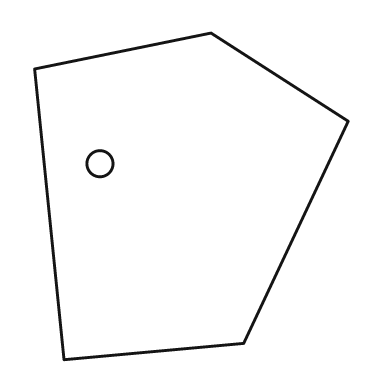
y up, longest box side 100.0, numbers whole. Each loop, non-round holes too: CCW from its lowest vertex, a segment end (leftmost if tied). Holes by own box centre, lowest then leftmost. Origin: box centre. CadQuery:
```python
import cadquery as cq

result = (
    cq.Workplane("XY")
    .moveTo(-39.0, -50.0)
    .lineTo(16.0, -45.0)
    .lineTo(48.0, 23.0)
    .lineTo(6.0, 50.0)
    .lineTo(-48.0, 39.0)
    .close()
    .moveTo(-28.0, 10.0)
    .circle(4.0)
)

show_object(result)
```